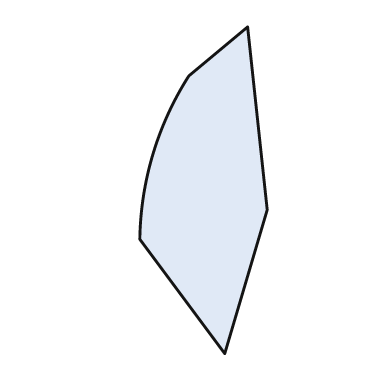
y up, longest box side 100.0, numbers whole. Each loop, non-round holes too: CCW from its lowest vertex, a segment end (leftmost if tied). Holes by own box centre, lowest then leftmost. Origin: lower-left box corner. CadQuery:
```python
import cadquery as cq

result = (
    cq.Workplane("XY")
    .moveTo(26.0, 0.0)
    .lineTo(39.0, 44.0)
    .lineTo(33.0, 100.0)
    .lineTo(15.0, 85.0)
    .threePointArc((4.0, 61.0), (0.0, 35.0))
    .close()
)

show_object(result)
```